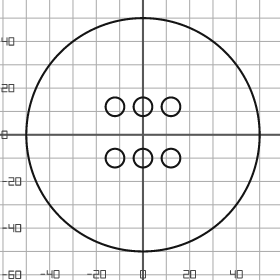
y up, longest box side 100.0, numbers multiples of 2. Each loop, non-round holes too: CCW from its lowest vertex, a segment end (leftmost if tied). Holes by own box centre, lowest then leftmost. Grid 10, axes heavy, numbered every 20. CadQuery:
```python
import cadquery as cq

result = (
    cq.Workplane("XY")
    .moveTo(0.0, 0.0)
    .circle(50.0)
    .moveTo(-12.0, -10.0)
    .circle(4.0)
    .moveTo(0.0, -10.0)
    .circle(4.0)
    .moveTo(12.0, -10.0)
    .circle(4.0)
    .moveTo(-12.0, 12.0)
    .circle(4.0)
    .moveTo(0.0, 12.0)
    .circle(4.0)
    .moveTo(12.0, 12.0)
    .circle(4.0)
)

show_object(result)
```